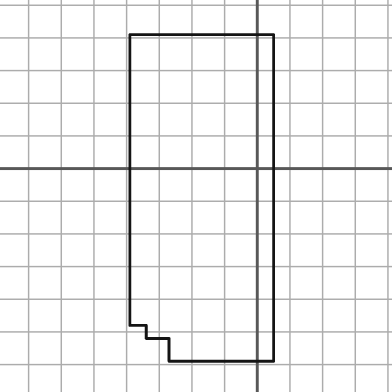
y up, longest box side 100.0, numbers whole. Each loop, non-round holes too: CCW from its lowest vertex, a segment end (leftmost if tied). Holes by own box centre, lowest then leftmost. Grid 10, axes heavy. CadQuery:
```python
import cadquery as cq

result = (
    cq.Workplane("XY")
    .moveTo(-27.0, -59.0)
    .lineTo(5.0, -59.0)
    .lineTo(5.0, 41.0)
    .lineTo(-39.0, 41.0)
    .lineTo(-39.0, -48.0)
    .lineTo(-34.0, -48.0)
    .lineTo(-34.0, -52.0)
    .lineTo(-27.0, -52.0)
    .close()
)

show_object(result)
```